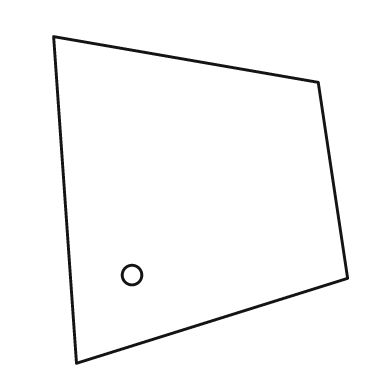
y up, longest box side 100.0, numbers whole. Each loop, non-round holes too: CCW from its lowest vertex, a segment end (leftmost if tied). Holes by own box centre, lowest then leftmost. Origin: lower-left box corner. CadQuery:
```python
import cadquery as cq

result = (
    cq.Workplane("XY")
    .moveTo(7.0, 0.0)
    .lineTo(90.0, 26.0)
    .lineTo(81.0, 86.0)
    .lineTo(0.0, 100.0)
    .close()
    .moveTo(24.0, 27.0)
    .circle(3.0)
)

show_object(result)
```